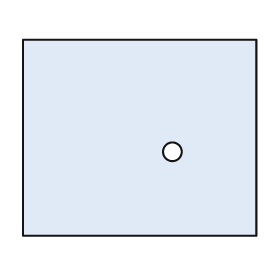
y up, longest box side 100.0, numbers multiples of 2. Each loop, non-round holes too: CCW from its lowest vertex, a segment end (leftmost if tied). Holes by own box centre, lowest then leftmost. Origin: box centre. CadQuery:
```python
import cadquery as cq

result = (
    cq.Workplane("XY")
    .moveTo(-50.0, -42.0)
    .lineTo(50.0, -42.0)
    .lineTo(50.0, 42.0)
    .lineTo(-50.0, 42.0)
    .close()
    .moveTo(14.0, -6.0)
    .circle(4.0)
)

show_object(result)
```